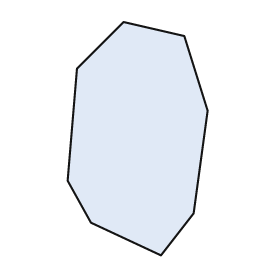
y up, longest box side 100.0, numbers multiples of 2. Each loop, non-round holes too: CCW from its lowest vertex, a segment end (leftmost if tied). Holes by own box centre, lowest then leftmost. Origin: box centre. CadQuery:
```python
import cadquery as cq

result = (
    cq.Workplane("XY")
    .moveTo(10.0, -50.0)
    .lineTo(24.0, -32.0)
    .lineTo(30.0, 12.0)
    .lineTo(20.0, 44.0)
    .lineTo(-6.0, 50.0)
    .lineTo(-26.0, 30.0)
    .lineTo(-30.0, -18.0)
    .lineTo(-20.0, -36.0)
    .close()
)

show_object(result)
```